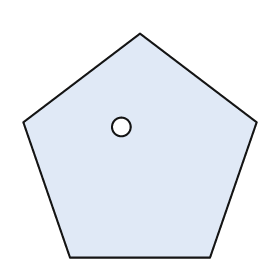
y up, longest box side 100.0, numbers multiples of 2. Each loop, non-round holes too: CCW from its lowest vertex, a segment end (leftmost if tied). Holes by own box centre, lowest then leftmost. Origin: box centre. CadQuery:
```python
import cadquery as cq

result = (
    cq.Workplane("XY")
    .moveTo(-30.0, -48.0)
    .lineTo(30.0, -48.0)
    .lineTo(50.0, 10.0)
    .lineTo(0.0, 48.0)
    .lineTo(-50.0, 10.0)
    .close()
    .moveTo(-8.0, 8.0)
    .circle(4.0)
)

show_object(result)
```